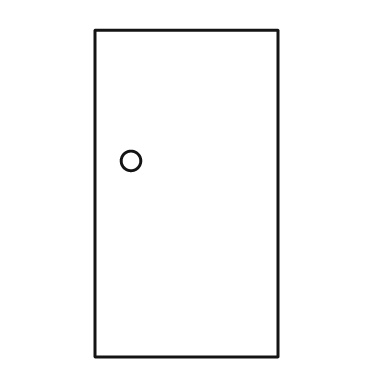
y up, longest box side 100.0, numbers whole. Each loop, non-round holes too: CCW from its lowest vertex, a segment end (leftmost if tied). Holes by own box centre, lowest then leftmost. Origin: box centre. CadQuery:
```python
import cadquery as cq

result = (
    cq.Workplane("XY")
    .moveTo(-28.0, -50.0)
    .lineTo(28.0, -50.0)
    .lineTo(28.0, 50.0)
    .lineTo(-28.0, 50.0)
    .close()
    .moveTo(-17.0, 10.0)
    .circle(3.0)
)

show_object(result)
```